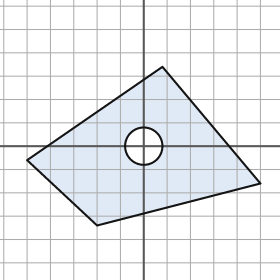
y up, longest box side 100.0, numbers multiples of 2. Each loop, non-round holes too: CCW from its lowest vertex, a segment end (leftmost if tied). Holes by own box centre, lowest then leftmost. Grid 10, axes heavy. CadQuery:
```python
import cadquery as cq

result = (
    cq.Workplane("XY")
    .moveTo(-20.0, -34.0)
    .lineTo(50.0, -16.0)
    .lineTo(8.0, 34.0)
    .lineTo(-50.0, -6.0)
    .close()
    .moveTo(0.0, 0.0)
    .circle(8.0)
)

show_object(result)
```